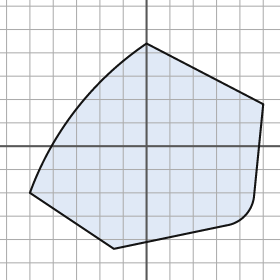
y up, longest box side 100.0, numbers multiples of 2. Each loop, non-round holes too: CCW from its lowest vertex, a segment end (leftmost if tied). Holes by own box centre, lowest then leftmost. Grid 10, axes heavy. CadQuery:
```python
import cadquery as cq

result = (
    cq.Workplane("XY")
    .moveTo(-14.0, -44.0)
    .lineTo(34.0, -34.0)
    .threePointArc((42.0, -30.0), (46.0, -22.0))
    .lineTo(50.0, 18.0)
    .lineTo(0.0, 44.0)
    .threePointArc((-30.0, 16.0), (-50.0, -20.0))
    .close()
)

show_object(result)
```